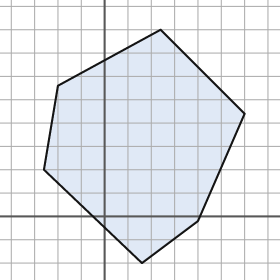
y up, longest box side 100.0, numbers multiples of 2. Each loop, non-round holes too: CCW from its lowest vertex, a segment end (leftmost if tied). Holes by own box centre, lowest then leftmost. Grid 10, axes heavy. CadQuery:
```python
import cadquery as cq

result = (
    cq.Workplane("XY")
    .moveTo(16.0, -20.0)
    .lineTo(40.0, -2.0)
    .lineTo(60.0, 44.0)
    .lineTo(24.0, 80.0)
    .lineTo(-20.0, 56.0)
    .lineTo(-26.0, 20.0)
    .close()
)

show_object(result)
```